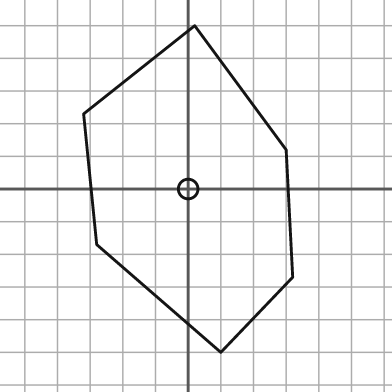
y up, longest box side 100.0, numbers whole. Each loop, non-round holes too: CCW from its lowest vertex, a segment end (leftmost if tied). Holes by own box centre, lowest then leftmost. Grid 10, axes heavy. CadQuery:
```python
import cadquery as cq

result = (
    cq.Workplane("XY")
    .moveTo(10.0, -50.0)
    .lineTo(32.0, -27.0)
    .lineTo(30.0, 12.0)
    .lineTo(2.0, 50.0)
    .lineTo(-32.0, 23.0)
    .lineTo(-28.0, -17.0)
    .close()
    .moveTo(0.0, 0.0)
    .circle(3.0)
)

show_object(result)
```